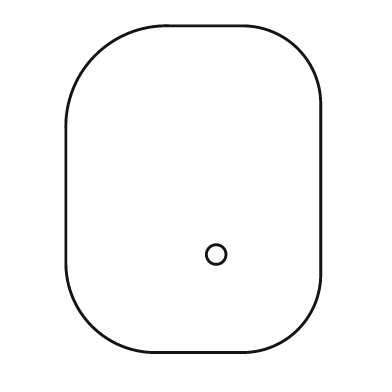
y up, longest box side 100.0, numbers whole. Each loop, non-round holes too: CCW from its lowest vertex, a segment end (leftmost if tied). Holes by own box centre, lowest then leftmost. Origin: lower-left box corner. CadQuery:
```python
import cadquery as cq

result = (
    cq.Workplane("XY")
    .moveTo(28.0, 0.0)
    .lineTo(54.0, 0.0)
    .threePointArc((71.0, 7.0), (78.0, 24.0))
    .lineTo(78.0, 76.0)
    .threePointArc((71.0, 93.0), (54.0, 100.0))
    .lineTo(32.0, 100.0)
    .threePointArc((9.0, 91.0), (0.0, 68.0))
    .lineTo(0.0, 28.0)
    .threePointArc((8.0, 8.0), (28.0, 0.0))
    .close()
    .moveTo(46.0, 30.0)
    .circle(3.0)
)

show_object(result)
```